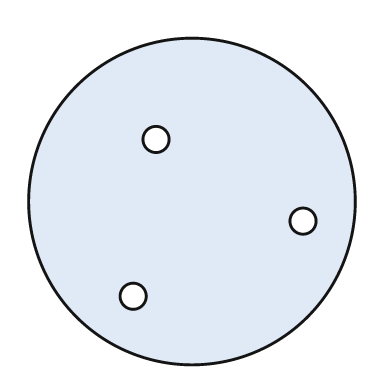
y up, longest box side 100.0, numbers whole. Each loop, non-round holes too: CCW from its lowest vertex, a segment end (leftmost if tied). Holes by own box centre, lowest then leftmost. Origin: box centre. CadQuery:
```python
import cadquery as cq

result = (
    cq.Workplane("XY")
    .moveTo(0.0, 0.0)
    .circle(50.0)
    .moveTo(-18.0, -29.0)
    .circle(4.0)
    .moveTo(34.0, -6.0)
    .circle(4.0)
    .moveTo(-11.0, 19.0)
    .circle(4.0)
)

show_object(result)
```